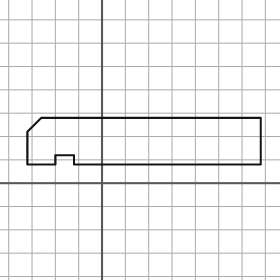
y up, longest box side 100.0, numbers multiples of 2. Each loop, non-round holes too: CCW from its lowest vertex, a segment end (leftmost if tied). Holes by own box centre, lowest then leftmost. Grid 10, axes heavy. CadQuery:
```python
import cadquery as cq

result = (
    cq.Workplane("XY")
    .moveTo(-32.0, 8.0)
    .lineTo(-20.0, 8.0)
    .lineTo(-20.0, 12.0)
    .lineTo(-12.0, 12.0)
    .lineTo(-12.0, 8.0)
    .lineTo(68.0, 8.0)
    .lineTo(68.0, 28.0)
    .lineTo(-26.0, 28.0)
    .lineTo(-32.0, 22.0)
    .close()
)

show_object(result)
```